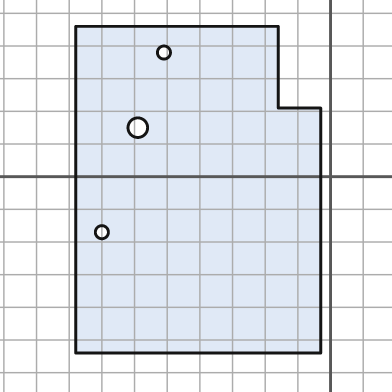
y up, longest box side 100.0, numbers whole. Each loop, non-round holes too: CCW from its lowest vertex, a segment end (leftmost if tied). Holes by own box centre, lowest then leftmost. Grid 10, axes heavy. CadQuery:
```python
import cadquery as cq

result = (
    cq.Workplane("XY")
    .moveTo(-78.0, -54.0)
    .lineTo(-3.0, -54.0)
    .lineTo(-3.0, 21.0)
    .lineTo(-16.0, 21.0)
    .lineTo(-16.0, 46.0)
    .lineTo(-78.0, 46.0)
    .close()
    .moveTo(-70.0, -17.0)
    .circle(2.0)
    .moveTo(-59.0, 15.0)
    .circle(3.0)
    .moveTo(-51.0, 38.0)
    .circle(2.0)
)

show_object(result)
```